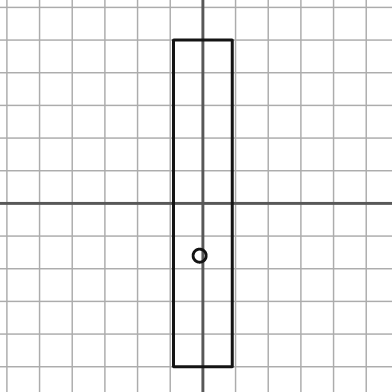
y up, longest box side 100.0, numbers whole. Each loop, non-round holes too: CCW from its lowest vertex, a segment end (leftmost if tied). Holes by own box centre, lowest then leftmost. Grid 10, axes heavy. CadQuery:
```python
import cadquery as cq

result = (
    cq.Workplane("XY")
    .moveTo(-9.0, -50.0)
    .lineTo(9.0, -50.0)
    .lineTo(9.0, 50.0)
    .lineTo(-9.0, 50.0)
    .close()
    .moveTo(-1.0, -16.0)
    .circle(2.0)
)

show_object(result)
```